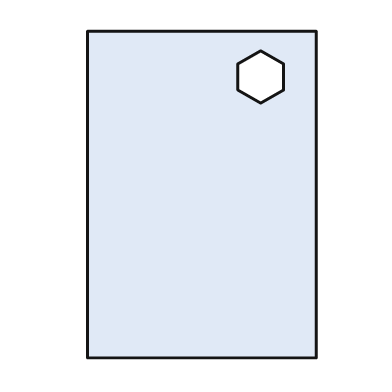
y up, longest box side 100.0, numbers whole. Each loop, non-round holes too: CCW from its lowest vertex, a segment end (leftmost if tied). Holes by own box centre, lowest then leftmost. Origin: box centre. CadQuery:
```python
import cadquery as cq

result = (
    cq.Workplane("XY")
    .moveTo(-35.0, -50.0)
    .lineTo(35.0, -50.0)
    .lineTo(35.0, 50.0)
    .lineTo(-35.0, 50.0)
    .close()
    .moveTo(18.0, 28.0)
    .lineTo(25.0, 32.0)
    .lineTo(25.0, 40.0)
    .lineTo(18.0, 44.0)
    .lineTo(11.0, 40.0)
    .lineTo(11.0, 32.0)
    .close()
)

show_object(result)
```